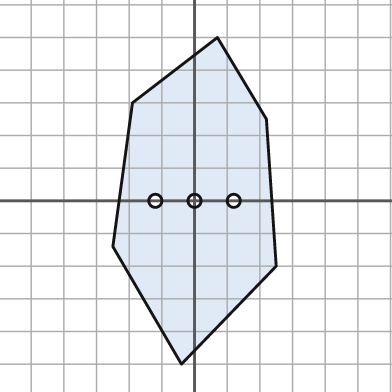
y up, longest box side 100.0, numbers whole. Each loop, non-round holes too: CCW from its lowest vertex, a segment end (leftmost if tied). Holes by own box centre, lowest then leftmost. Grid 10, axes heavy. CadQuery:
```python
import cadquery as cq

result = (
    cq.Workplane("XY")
    .moveTo(-4.0, -50.0)
    .lineTo(25.0, -20.0)
    .lineTo(22.0, 25.0)
    .lineTo(7.0, 50.0)
    .lineTo(-19.0, 30.0)
    .lineTo(-25.0, -14.0)
    .close()
    .moveTo(-12.0, 0.0)
    .circle(2.0)
    .moveTo(0.0, 0.0)
    .circle(2.0)
    .moveTo(12.0, 0.0)
    .circle(2.0)
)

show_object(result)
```